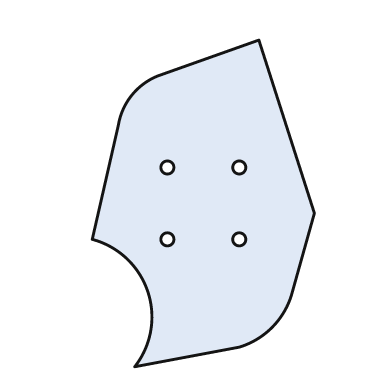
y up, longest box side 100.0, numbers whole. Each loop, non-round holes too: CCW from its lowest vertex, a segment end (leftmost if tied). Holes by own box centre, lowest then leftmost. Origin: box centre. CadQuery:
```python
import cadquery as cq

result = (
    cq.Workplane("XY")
    .moveTo(-21.0, -50.0)
    .lineTo(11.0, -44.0)
    .threePointArc((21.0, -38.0), (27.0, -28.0))
    .lineTo(34.0, -3.0)
    .lineTo(17.0, 50.0)
    .lineTo(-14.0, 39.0)
    .threePointArc((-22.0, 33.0), (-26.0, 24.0))
    .lineTo(-34.0, -11.0)
    .threePointArc((-17.0, -27.0), (-21.0, -50.0))
    .close()
    .moveTo(-11.0, -11.0)
    .circle(2.0)
    .moveTo(11.0, -11.0)
    .circle(2.0)
    .moveTo(-11.0, 11.0)
    .circle(2.0)
    .moveTo(11.0, 11.0)
    .circle(2.0)
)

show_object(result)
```